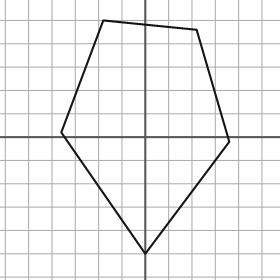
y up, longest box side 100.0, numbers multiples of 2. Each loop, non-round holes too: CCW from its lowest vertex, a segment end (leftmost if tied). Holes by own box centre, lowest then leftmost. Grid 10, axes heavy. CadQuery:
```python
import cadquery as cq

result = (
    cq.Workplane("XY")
    .moveTo(0.0, -50.0)
    .lineTo(36.0, -2.0)
    .lineTo(22.0, 46.0)
    .lineTo(-18.0, 50.0)
    .lineTo(-36.0, 2.0)
    .close()
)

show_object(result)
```